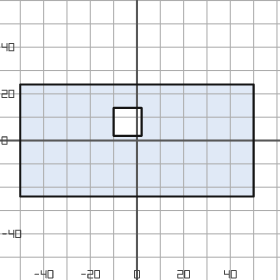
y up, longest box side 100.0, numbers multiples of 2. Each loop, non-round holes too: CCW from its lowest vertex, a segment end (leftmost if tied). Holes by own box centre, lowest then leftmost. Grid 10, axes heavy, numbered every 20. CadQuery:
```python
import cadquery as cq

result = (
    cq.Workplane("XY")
    .moveTo(-50.0, -24.0)
    .lineTo(50.0, -24.0)
    .lineTo(50.0, 24.0)
    .lineTo(-50.0, 24.0)
    .close()
    .moveTo(-10.0, 2.0)
    .lineTo(2.0, 2.0)
    .lineTo(2.0, 14.0)
    .lineTo(-10.0, 14.0)
    .close()
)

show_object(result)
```